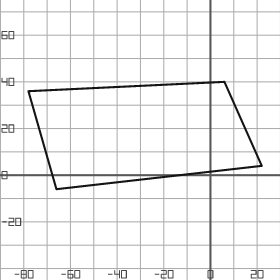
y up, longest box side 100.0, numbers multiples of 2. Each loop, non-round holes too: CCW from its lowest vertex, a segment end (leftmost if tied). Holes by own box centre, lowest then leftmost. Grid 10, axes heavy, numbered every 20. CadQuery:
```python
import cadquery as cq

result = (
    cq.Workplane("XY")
    .moveTo(-66.0, -6.0)
    .lineTo(22.0, 4.0)
    .lineTo(6.0, 40.0)
    .lineTo(-78.0, 36.0)
    .close()
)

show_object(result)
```